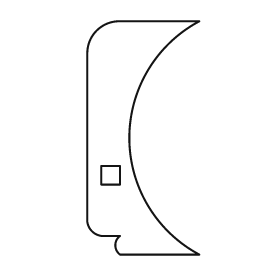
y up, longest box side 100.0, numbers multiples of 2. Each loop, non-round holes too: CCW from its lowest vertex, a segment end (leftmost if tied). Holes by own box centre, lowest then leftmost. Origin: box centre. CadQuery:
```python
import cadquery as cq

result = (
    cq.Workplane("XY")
    .moveTo(-10.0, -50.0)
    .lineTo(24.0, -50.0)
    .threePointArc((-6.0, 0.0), (24.0, 50.0))
    .lineTo(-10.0, 50.0)
    .threePointArc((-20.0, 46.0), (-24.0, 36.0))
    .lineTo(-24.0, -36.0)
    .threePointArc((-22.0, -40.0), (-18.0, -42.0))
    .lineTo(-10.0, -42.0)
    .threePointArc((-12.0, -46.0), (-10.0, -50.0))
    .close()
    .moveTo(-18.0, -20.0)
    .lineTo(-10.0, -20.0)
    .lineTo(-10.0, -12.0)
    .lineTo(-18.0, -12.0)
    .close()
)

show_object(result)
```